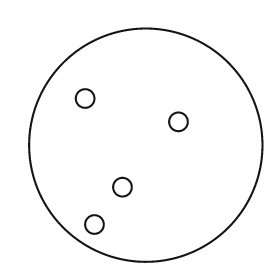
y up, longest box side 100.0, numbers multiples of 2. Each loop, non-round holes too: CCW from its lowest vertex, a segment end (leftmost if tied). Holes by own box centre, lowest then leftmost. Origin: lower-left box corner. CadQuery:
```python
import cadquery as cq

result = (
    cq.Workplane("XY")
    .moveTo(50.0, 50.0)
    .circle(50.0)
    .moveTo(28.0, 16.0)
    .circle(4.0)
    .moveTo(40.0, 32.0)
    .circle(4.0)
    .moveTo(64.0, 60.0)
    .circle(4.0)
    .moveTo(24.0, 70.0)
    .circle(4.0)
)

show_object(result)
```